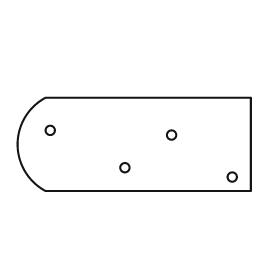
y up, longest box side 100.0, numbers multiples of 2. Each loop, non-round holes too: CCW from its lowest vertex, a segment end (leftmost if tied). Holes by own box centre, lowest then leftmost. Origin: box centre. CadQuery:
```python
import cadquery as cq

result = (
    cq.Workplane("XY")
    .moveTo(-38.0, -20.0)
    .lineTo(50.0, -20.0)
    .lineTo(50.0, 20.0)
    .lineTo(-38.0, 20.0)
    .threePointArc((-50.0, 0.0), (-38.0, -20.0))
    .close()
    .moveTo(42.0, -14.0)
    .circle(2.0)
    .moveTo(-4.0, -10.0)
    .circle(2.0)
    .moveTo(16.0, 4.0)
    .circle(2.0)
    .moveTo(-36.0, 6.0)
    .circle(2.0)
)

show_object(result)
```